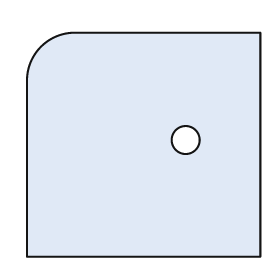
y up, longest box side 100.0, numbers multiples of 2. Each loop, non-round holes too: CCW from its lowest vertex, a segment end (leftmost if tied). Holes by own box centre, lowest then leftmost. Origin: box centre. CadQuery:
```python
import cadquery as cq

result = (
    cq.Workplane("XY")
    .moveTo(-50.0, -48.0)
    .lineTo(50.0, -48.0)
    .lineTo(50.0, 48.0)
    .lineTo(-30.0, 48.0)
    .threePointArc((-44.0, 42.0), (-50.0, 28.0))
    .close()
    .moveTo(18.0, 2.0)
    .circle(6.0)
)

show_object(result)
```